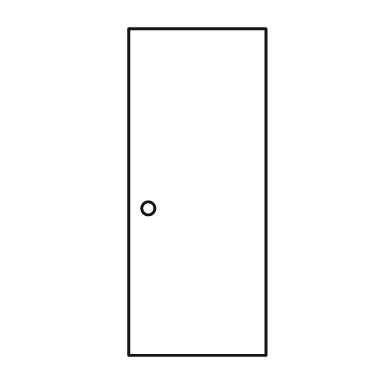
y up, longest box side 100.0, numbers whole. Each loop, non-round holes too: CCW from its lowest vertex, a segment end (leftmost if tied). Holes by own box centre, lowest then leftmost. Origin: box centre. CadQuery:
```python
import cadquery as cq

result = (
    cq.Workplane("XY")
    .moveTo(-21.0, -50.0)
    .lineTo(21.0, -50.0)
    .lineTo(21.0, 50.0)
    .lineTo(-21.0, 50.0)
    .close()
    .moveTo(-15.0, -5.0)
    .circle(2.0)
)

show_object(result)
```